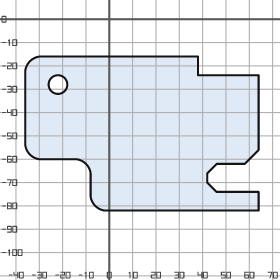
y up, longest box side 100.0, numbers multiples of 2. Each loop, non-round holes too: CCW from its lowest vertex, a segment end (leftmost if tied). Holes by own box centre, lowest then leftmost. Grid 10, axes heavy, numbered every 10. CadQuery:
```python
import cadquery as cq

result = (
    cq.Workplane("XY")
    .moveTo(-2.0, -82.0)
    .lineTo(64.0, -82.0)
    .lineTo(64.0, -74.0)
    .lineTo(46.0, -74.0)
    .lineTo(42.0, -70.0)
    .lineTo(42.0, -66.0)
    .lineTo(46.0, -62.0)
    .lineTo(58.0, -62.0)
    .lineTo(64.0, -56.0)
    .lineTo(64.0, -24.0)
    .lineTo(38.0, -24.0)
    .lineTo(38.0, -16.0)
    .lineTo(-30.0, -16.0)
    .threePointArc((-34.0, -18.0), (-36.0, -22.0))
    .lineTo(-36.0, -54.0)
    .threePointArc((-34.0, -58.0), (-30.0, -60.0))
    .lineTo(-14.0, -60.0)
    .threePointArc((-10.0, -62.0), (-8.0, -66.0))
    .lineTo(-8.0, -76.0)
    .threePointArc((-6.0, -80.0), (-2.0, -82.0))
    .close()
    .moveTo(-22.0, -28.0)
    .circle(4.0)
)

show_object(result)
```